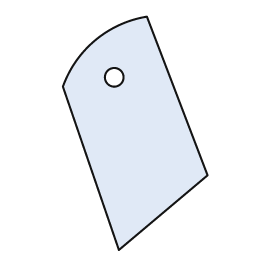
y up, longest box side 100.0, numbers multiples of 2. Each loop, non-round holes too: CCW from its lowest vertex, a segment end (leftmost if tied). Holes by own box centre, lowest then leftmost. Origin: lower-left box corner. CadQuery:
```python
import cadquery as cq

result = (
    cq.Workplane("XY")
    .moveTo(24.0, 0.0)
    .lineTo(62.0, 32.0)
    .lineTo(36.0, 100.0)
    .threePointArc((14.0, 90.0), (0.0, 70.0))
    .close()
    .moveTo(22.0, 74.0)
    .circle(4.0)
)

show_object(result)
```